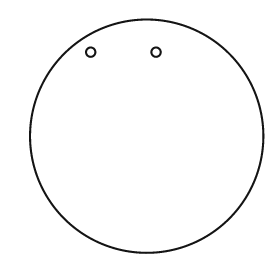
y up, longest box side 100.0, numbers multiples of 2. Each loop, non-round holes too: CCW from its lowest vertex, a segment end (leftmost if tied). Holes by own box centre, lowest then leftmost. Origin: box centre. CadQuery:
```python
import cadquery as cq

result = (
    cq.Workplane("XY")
    .moveTo(0.0, 0.0)
    .circle(50.0)
    .moveTo(-24.0, 36.0)
    .circle(2.0)
    .moveTo(4.0, 36.0)
    .circle(2.0)
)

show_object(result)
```